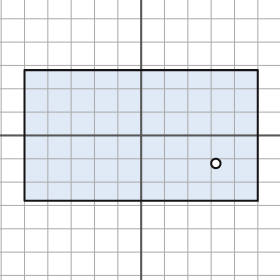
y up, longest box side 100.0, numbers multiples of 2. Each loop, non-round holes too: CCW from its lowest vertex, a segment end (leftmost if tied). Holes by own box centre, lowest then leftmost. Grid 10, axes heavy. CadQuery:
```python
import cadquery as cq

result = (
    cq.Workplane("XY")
    .moveTo(-50.0, -28.0)
    .lineTo(50.0, -28.0)
    .lineTo(50.0, 28.0)
    .lineTo(-50.0, 28.0)
    .close()
    .moveTo(32.0, -12.0)
    .circle(2.0)
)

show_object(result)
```